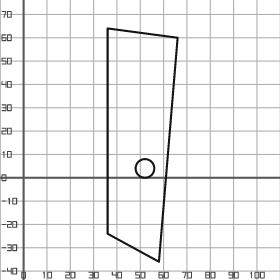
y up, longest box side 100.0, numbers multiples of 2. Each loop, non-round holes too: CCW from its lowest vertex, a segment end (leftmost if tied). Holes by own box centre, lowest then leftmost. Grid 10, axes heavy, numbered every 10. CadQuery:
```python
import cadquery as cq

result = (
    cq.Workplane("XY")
    .moveTo(58.0, -36.0)
    .lineTo(66.0, 60.0)
    .lineTo(36.0, 64.0)
    .lineTo(36.0, -24.0)
    .close()
    .moveTo(52.0, 4.0)
    .circle(4.0)
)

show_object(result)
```